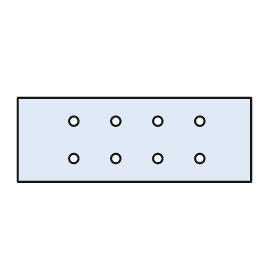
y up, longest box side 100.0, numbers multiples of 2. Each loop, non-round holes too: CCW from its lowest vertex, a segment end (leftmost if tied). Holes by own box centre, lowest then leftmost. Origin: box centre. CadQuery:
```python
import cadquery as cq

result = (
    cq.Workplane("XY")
    .moveTo(-50.0, -18.0)
    .lineTo(50.0, -18.0)
    .lineTo(50.0, 18.0)
    .lineTo(-50.0, 18.0)
    .close()
    .moveTo(-26.0, -8.0)
    .circle(2.0)
    .moveTo(-8.0, -8.0)
    .circle(2.0)
    .moveTo(10.0, -8.0)
    .circle(2.0)
    .moveTo(28.0, -8.0)
    .circle(2.0)
    .moveTo(-26.0, 8.0)
    .circle(2.0)
    .moveTo(-8.0, 8.0)
    .circle(2.0)
    .moveTo(10.0, 8.0)
    .circle(2.0)
    .moveTo(28.0, 8.0)
    .circle(2.0)
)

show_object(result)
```